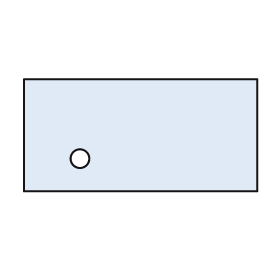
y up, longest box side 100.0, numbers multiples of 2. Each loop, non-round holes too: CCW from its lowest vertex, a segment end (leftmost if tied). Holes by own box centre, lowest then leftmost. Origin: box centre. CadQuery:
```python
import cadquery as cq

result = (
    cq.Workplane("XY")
    .moveTo(-50.0, -24.0)
    .lineTo(50.0, -24.0)
    .lineTo(50.0, 24.0)
    .lineTo(-50.0, 24.0)
    .close()
    .moveTo(-26.0, -10.0)
    .circle(4.0)
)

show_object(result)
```